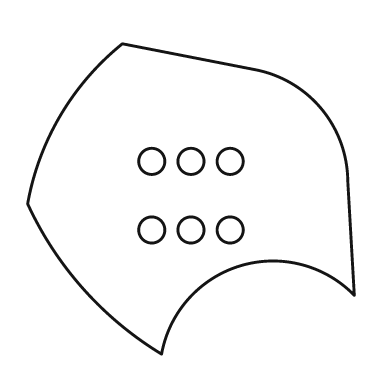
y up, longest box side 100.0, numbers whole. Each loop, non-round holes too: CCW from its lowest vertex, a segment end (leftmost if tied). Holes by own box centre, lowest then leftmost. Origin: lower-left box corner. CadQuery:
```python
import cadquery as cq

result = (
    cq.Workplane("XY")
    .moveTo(41.0, 0.0)
    .threePointArc((65.0, 27.0), (100.0, 18.0))
    .lineTo(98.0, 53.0)
    .threePointArc((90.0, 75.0), (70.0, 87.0))
    .lineTo(29.0, 95.0)
    .threePointArc((10.0, 73.0), (0.0, 46.0))
    .threePointArc((17.0, 20.0), (41.0, 0.0))
    .close()
    .moveTo(38.0, 38.0)
    .circle(4.0)
    .moveTo(50.0, 38.0)
    .circle(4.0)
    .moveTo(62.0, 38.0)
    .circle(4.0)
    .moveTo(38.0, 59.0)
    .circle(4.0)
    .moveTo(50.0, 59.0)
    .circle(4.0)
    .moveTo(62.0, 59.0)
    .circle(4.0)
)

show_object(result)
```